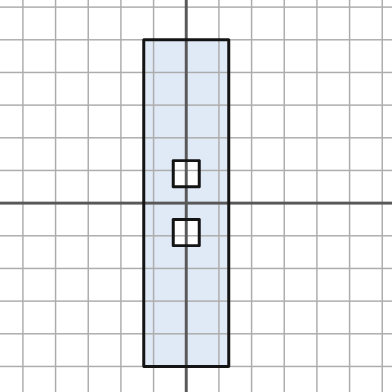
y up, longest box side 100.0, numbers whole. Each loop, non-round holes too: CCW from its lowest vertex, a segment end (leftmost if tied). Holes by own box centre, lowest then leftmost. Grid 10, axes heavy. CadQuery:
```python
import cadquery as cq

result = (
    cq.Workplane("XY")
    .moveTo(-13.0, -50.0)
    .lineTo(13.0, -50.0)
    .lineTo(13.0, 50.0)
    .lineTo(-13.0, 50.0)
    .close()
    .moveTo(-4.0, -13.0)
    .lineTo(4.0, -13.0)
    .lineTo(4.0, -5.0)
    .lineTo(-4.0, -5.0)
    .close()
    .moveTo(-4.0, 5.0)
    .lineTo(4.0, 5.0)
    .lineTo(4.0, 13.0)
    .lineTo(-4.0, 13.0)
    .close()
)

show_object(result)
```